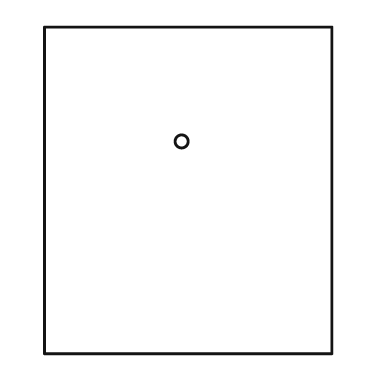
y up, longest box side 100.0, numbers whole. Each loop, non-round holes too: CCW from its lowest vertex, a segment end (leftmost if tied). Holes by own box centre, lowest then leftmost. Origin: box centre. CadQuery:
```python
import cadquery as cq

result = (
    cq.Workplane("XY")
    .moveTo(-44.0, -50.0)
    .lineTo(44.0, -50.0)
    .lineTo(44.0, 50.0)
    .lineTo(-44.0, 50.0)
    .close()
    .moveTo(-2.0, 15.0)
    .circle(2.0)
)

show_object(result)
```